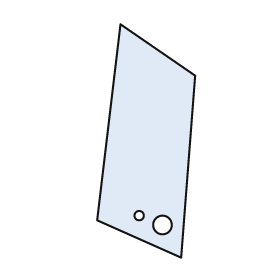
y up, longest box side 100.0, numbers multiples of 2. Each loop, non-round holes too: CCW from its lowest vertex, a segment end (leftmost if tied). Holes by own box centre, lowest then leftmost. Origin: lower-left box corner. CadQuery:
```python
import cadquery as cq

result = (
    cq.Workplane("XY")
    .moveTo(36.0, 0.0)
    .lineTo(42.0, 78.0)
    .lineTo(10.0, 100.0)
    .lineTo(0.0, 16.0)
    .close()
    .moveTo(28.0, 14.0)
    .circle(4.0)
    .moveTo(18.0, 18.0)
    .circle(2.0)
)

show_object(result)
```